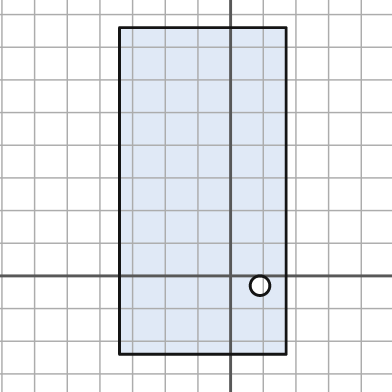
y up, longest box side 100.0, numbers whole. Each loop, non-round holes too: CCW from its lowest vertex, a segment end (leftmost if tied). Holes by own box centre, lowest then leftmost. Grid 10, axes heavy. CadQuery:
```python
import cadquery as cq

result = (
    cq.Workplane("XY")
    .moveTo(-34.0, -24.0)
    .lineTo(17.0, -24.0)
    .lineTo(17.0, 76.0)
    .lineTo(-34.0, 76.0)
    .close()
    .moveTo(9.0, -3.0)
    .circle(3.0)
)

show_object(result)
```